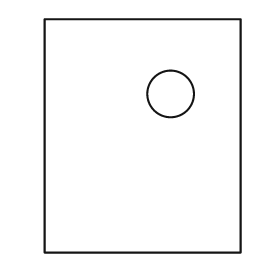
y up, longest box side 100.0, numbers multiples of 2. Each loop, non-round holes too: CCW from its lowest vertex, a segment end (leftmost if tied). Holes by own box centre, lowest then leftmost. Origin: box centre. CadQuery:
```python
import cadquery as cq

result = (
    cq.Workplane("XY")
    .moveTo(-42.0, -50.0)
    .lineTo(42.0, -50.0)
    .lineTo(42.0, 50.0)
    .lineTo(-42.0, 50.0)
    .close()
    .moveTo(12.0, 18.0)
    .circle(10.0)
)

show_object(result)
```